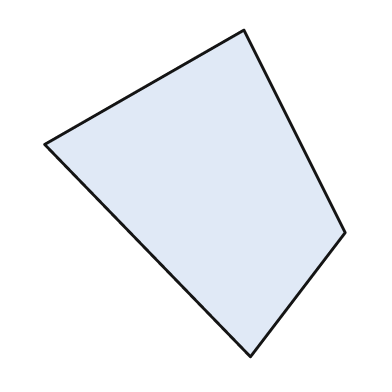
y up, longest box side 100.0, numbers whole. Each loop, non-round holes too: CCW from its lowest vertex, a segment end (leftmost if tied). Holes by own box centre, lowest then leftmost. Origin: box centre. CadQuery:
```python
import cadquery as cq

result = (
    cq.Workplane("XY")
    .moveTo(17.0, -50.0)
    .lineTo(46.0, -12.0)
    .lineTo(15.0, 50.0)
    .lineTo(-46.0, 15.0)
    .close()
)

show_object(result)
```